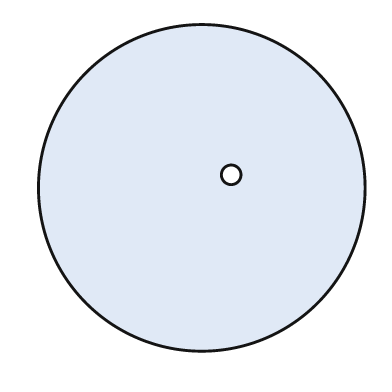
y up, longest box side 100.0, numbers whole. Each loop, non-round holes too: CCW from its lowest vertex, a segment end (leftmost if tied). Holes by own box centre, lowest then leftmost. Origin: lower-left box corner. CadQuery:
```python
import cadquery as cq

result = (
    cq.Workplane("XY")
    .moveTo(50.0, 50.0)
    .circle(50.0)
    .moveTo(59.0, 54.0)
    .circle(3.0)
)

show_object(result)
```